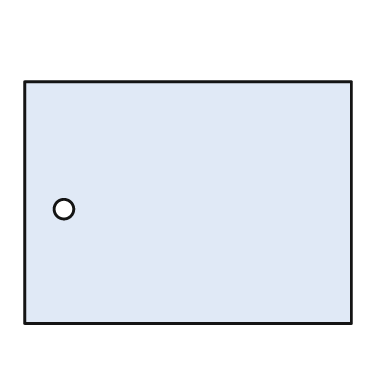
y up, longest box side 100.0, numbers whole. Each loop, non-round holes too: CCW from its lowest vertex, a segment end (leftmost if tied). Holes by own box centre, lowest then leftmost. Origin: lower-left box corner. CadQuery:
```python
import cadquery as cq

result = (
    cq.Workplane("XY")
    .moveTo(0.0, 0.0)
    .lineTo(100.0, 0.0)
    .lineTo(100.0, 74.0)
    .lineTo(0.0, 74.0)
    .close()
    .moveTo(12.0, 35.0)
    .circle(3.0)
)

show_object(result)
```